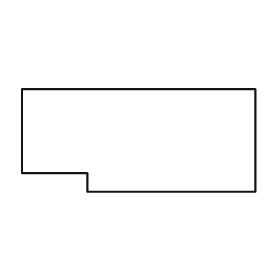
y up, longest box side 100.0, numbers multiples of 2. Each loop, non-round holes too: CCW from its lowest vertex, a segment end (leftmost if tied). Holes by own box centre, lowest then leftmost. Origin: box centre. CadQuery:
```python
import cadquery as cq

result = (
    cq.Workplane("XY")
    .moveTo(-22.0, -22.0)
    .lineTo(50.0, -22.0)
    .lineTo(50.0, 22.0)
    .lineTo(-50.0, 22.0)
    .lineTo(-50.0, -14.0)
    .lineTo(-22.0, -14.0)
    .close()
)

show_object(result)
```